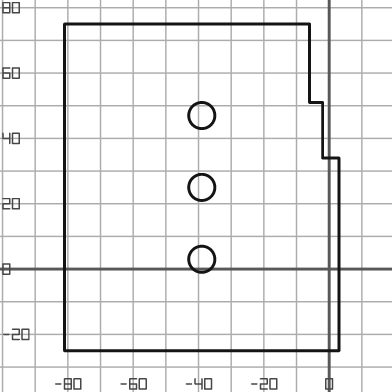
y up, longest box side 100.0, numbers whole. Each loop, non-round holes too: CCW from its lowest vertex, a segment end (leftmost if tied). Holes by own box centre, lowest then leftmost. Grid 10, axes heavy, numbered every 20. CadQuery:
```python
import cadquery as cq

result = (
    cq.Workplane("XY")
    .moveTo(-81.0, -25.0)
    .lineTo(3.0, -25.0)
    .lineTo(3.0, 34.0)
    .lineTo(-2.0, 34.0)
    .lineTo(-2.0, 51.0)
    .lineTo(-6.0, 51.0)
    .lineTo(-6.0, 75.0)
    .lineTo(-81.0, 75.0)
    .close()
    .moveTo(-39.0, 3.0)
    .circle(4.0)
    .moveTo(-39.0, 25.0)
    .circle(4.0)
    .moveTo(-39.0, 47.0)
    .circle(4.0)
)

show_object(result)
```